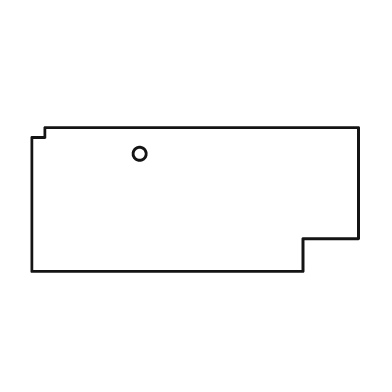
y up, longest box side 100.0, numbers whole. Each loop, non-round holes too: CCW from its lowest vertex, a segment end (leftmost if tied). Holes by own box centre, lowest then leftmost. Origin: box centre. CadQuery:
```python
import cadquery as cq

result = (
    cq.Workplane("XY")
    .moveTo(-50.0, -22.0)
    .lineTo(33.0, -22.0)
    .lineTo(33.0, -12.0)
    .lineTo(50.0, -12.0)
    .lineTo(50.0, 22.0)
    .lineTo(-46.0, 22.0)
    .lineTo(-46.0, 19.0)
    .lineTo(-50.0, 19.0)
    .close()
    .moveTo(-17.0, 14.0)
    .circle(2.0)
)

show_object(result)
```